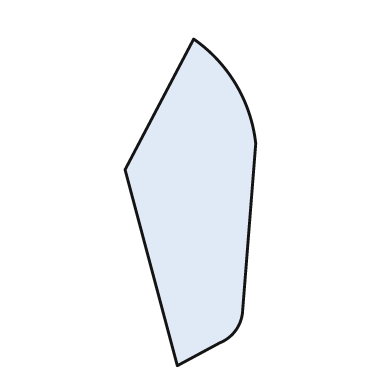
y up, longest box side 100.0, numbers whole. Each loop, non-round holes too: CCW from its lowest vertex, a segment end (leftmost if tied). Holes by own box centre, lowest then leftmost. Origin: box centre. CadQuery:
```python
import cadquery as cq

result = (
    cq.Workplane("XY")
    .moveTo(-4.0, -50.0)
    .lineTo(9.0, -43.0)
    .threePointArc((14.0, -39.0), (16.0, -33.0))
    .lineTo(20.0, 18.0)
    .threePointArc((14.0, 36.0), (1.0, 50.0))
    .lineTo(-20.0, 10.0)
    .close()
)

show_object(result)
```